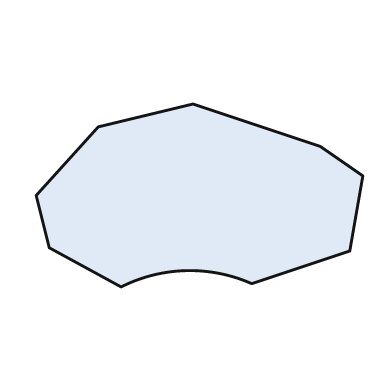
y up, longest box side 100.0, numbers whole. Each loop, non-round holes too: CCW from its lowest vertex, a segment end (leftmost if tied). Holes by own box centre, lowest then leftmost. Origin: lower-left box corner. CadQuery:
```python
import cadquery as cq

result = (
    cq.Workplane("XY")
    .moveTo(26.0, 0.0)
    .threePointArc((46.0, 5.0), (66.0, 1.0))
    .lineTo(96.0, 11.0)
    .lineTo(100.0, 34.0)
    .lineTo(87.0, 43.0)
    .lineTo(48.0, 56.0)
    .lineTo(19.0, 49.0)
    .lineTo(0.0, 28.0)
    .lineTo(4.0, 12.0)
    .close()
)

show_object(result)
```